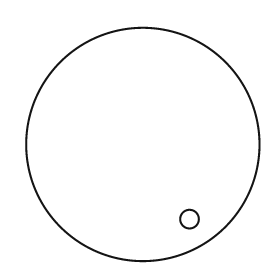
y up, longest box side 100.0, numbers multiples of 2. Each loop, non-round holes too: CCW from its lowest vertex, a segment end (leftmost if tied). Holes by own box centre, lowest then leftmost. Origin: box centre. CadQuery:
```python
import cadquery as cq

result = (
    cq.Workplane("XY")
    .moveTo(0.0, 0.0)
    .circle(50.0)
    .moveTo(20.0, -32.0)
    .circle(4.0)
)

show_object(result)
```